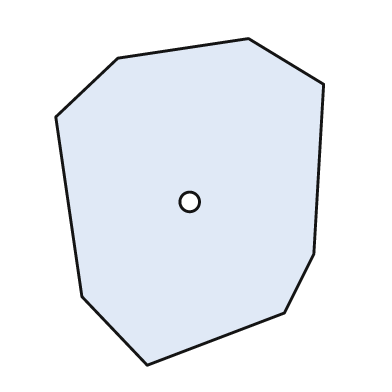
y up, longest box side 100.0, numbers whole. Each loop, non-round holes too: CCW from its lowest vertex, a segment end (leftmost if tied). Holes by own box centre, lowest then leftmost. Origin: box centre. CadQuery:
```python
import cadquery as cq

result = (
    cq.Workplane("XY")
    .moveTo(-13.0, -50.0)
    .lineTo(29.0, -34.0)
    .lineTo(38.0, -16.0)
    .lineTo(41.0, 36.0)
    .lineTo(18.0, 50.0)
    .lineTo(-22.0, 44.0)
    .lineTo(-41.0, 26.0)
    .lineTo(-33.0, -29.0)
    .close()
    .moveTo(0.0, 0.0)
    .circle(3.0)
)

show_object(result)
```